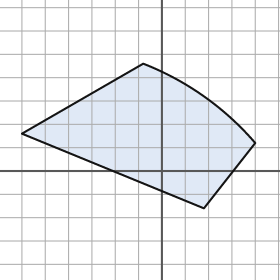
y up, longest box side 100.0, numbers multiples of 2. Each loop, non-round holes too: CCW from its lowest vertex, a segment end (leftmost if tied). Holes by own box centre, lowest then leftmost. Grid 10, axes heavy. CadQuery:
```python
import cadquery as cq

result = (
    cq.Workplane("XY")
    .moveTo(18.0, -16.0)
    .lineTo(40.0, 12.0)
    .threePointArc((18.0, 32.0), (-8.0, 46.0))
    .lineTo(-60.0, 16.0)
    .close()
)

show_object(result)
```